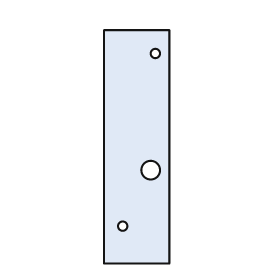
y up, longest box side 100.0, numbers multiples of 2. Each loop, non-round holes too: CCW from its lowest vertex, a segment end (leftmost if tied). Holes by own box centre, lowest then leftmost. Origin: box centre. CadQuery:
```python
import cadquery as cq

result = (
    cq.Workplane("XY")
    .moveTo(-14.0, -50.0)
    .lineTo(14.0, -50.0)
    .lineTo(14.0, 50.0)
    .lineTo(-14.0, 50.0)
    .close()
    .moveTo(-6.0, -34.0)
    .circle(2.0)
    .moveTo(6.0, -10.0)
    .circle(4.0)
    .moveTo(8.0, 40.0)
    .circle(2.0)
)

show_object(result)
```